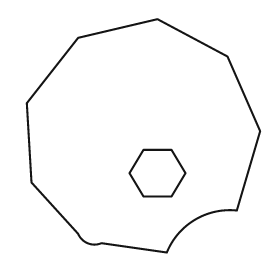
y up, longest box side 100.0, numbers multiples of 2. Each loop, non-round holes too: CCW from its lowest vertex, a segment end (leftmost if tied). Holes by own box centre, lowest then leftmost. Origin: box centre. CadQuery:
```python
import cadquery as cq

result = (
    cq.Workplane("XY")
    .moveTo(10.0, -50.0)
    .threePointArc((22.0, -36.0), (40.0, -32.0))
    .lineTo(50.0, 2.0)
    .lineTo(36.0, 34.0)
    .lineTo(6.0, 50.0)
    .lineTo(-28.0, 42.0)
    .lineTo(-50.0, 14.0)
    .lineTo(-48.0, -20.0)
    .lineTo(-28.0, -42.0)
    .threePointArc((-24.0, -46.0), (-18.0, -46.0))
    .close()
    .moveTo(0.0, -26.0)
    .lineTo(12.0, -26.0)
    .lineTo(18.0, -16.0)
    .lineTo(12.0, -6.0)
    .lineTo(0.0, -6.0)
    .lineTo(-6.0, -16.0)
    .close()
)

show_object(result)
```